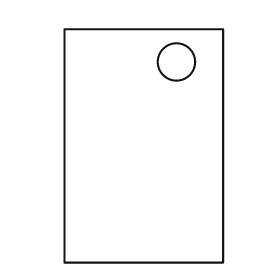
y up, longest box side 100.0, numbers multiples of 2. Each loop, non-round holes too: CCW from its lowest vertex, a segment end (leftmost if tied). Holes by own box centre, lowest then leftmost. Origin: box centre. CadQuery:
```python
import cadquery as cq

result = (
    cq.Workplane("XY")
    .moveTo(-34.0, -50.0)
    .lineTo(34.0, -50.0)
    .lineTo(34.0, 50.0)
    .lineTo(-34.0, 50.0)
    .close()
    .moveTo(14.0, 36.0)
    .circle(8.0)
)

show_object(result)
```